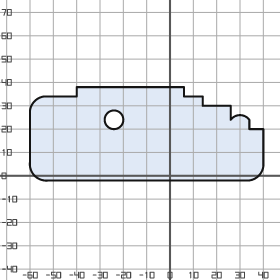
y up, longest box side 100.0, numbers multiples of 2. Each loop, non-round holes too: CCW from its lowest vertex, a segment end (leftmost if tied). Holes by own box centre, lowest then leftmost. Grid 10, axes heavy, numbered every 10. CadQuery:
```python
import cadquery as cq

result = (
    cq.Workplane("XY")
    .moveTo(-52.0, -2.0)
    .lineTo(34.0, -2.0)
    .threePointArc((38.0, 0.0), (40.0, 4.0))
    .lineTo(40.0, 20.0)
    .lineTo(34.0, 20.0)
    .lineTo(34.0, 24.0)
    .threePointArc((30.0, 26.0), (26.0, 24.0))
    .lineTo(26.0, 30.0)
    .lineTo(14.0, 30.0)
    .lineTo(14.0, 34.0)
    .lineTo(6.0, 34.0)
    .lineTo(6.0, 38.0)
    .lineTo(-40.0, 38.0)
    .lineTo(-40.0, 34.0)
    .lineTo(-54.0, 34.0)
    .threePointArc((-58.0, 32.0), (-60.0, 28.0))
    .lineTo(-60.0, 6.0)
    .threePointArc((-58.0, 0.0), (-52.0, -2.0))
    .close()
    .moveTo(-24.0, 24.0)
    .circle(4.0)
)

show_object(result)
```